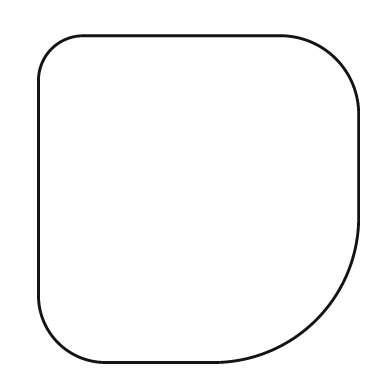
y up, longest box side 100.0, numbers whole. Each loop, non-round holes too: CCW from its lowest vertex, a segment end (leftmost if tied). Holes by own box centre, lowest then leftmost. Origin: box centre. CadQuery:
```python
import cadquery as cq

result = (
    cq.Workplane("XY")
    .moveTo(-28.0, -50.0)
    .lineTo(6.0, -50.0)
    .threePointArc((36.0, -37.0), (49.0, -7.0))
    .lineTo(49.0, 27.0)
    .threePointArc((42.0, 43.0), (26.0, 50.0))
    .lineTo(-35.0, 50.0)
    .threePointArc((-45.0, 46.0), (-49.0, 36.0))
    .lineTo(-49.0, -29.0)
    .threePointArc((-43.0, -44.0), (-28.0, -50.0))
    .close()
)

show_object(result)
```